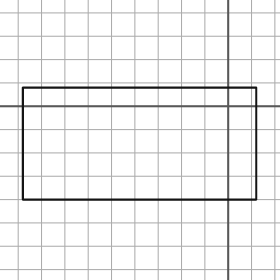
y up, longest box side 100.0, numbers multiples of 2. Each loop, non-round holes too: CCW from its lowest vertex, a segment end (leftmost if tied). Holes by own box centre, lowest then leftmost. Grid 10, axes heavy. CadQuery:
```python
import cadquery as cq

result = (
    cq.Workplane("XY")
    .moveTo(-88.0, -40.0)
    .lineTo(12.0, -40.0)
    .lineTo(12.0, 8.0)
    .lineTo(-88.0, 8.0)
    .close()
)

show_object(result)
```